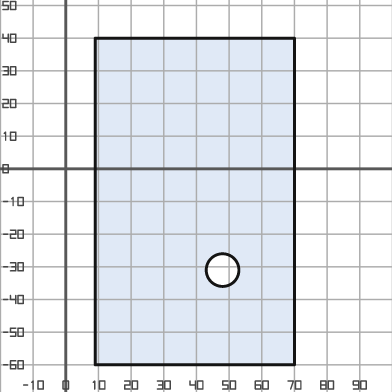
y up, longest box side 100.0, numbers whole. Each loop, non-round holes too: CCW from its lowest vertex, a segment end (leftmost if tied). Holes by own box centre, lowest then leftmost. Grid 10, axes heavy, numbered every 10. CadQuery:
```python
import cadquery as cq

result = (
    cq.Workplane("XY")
    .moveTo(9.0, -60.0)
    .lineTo(70.0, -60.0)
    .lineTo(70.0, 40.0)
    .lineTo(9.0, 40.0)
    .close()
    .moveTo(48.0, -31.0)
    .circle(5.0)
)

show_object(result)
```